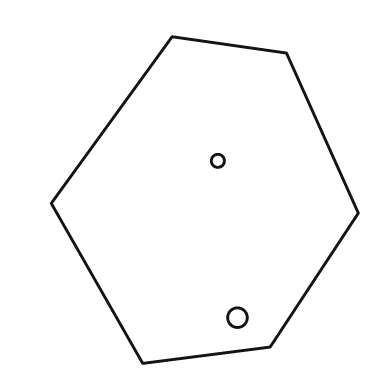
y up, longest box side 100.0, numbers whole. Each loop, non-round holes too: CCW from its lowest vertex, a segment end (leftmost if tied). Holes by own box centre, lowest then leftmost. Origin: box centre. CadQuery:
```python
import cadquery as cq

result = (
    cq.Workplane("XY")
    .moveTo(-19.0, -50.0)
    .lineTo(20.0, -45.0)
    .lineTo(47.0, -4.0)
    .lineTo(25.0, 45.0)
    .lineTo(-10.0, 50.0)
    .lineTo(-47.0, -1.0)
    .close()
    .moveTo(10.0, -36.0)
    .circle(3.0)
    .moveTo(4.0, 12.0)
    .circle(2.0)
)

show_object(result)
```